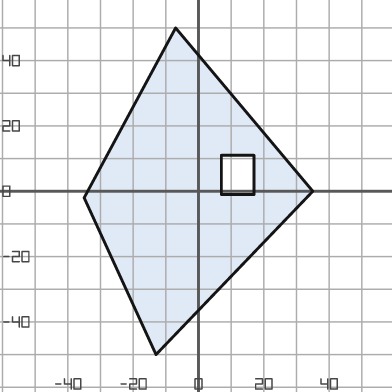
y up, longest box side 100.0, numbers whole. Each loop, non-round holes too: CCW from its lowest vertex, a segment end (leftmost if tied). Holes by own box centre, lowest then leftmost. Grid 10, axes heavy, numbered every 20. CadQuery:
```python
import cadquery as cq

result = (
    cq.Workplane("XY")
    .moveTo(-13.0, -50.0)
    .lineTo(35.0, 0.0)
    .lineTo(-7.0, 50.0)
    .lineTo(-35.0, -2.0)
    .close()
    .moveTo(7.0, -1.0)
    .lineTo(17.0, -1.0)
    .lineTo(17.0, 11.0)
    .lineTo(7.0, 11.0)
    .close()
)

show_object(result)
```